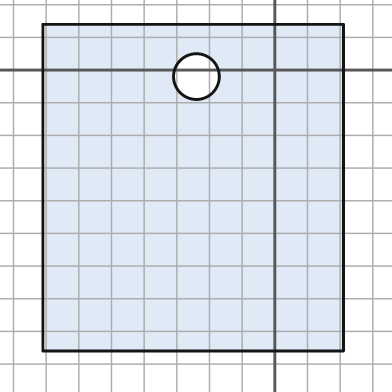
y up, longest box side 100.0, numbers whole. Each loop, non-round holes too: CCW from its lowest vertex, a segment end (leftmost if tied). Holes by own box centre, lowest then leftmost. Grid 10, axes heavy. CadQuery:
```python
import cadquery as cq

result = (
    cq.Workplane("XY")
    .moveTo(-71.0, -86.0)
    .lineTo(21.0, -86.0)
    .lineTo(21.0, 14.0)
    .lineTo(-71.0, 14.0)
    .close()
    .moveTo(-24.0, -2.0)
    .circle(7.0)
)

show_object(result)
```